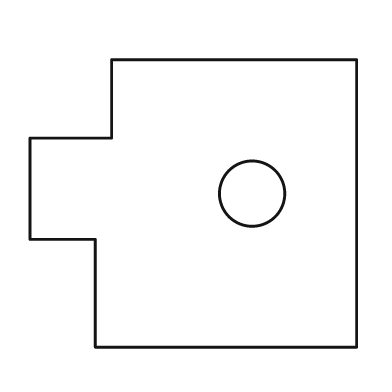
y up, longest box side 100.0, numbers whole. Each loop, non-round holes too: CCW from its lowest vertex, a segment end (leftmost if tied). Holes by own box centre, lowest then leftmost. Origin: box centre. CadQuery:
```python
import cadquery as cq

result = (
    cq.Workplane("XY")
    .moveTo(-30.0, -44.0)
    .lineTo(50.0, -44.0)
    .lineTo(50.0, 44.0)
    .lineTo(-25.0, 44.0)
    .lineTo(-25.0, 20.0)
    .lineTo(-50.0, 20.0)
    .lineTo(-50.0, -11.0)
    .lineTo(-30.0, -11.0)
    .close()
    .moveTo(18.0, 3.0)
    .circle(10.0)
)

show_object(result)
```